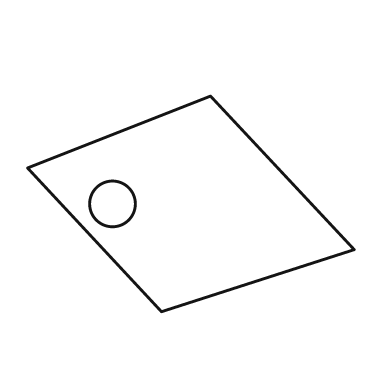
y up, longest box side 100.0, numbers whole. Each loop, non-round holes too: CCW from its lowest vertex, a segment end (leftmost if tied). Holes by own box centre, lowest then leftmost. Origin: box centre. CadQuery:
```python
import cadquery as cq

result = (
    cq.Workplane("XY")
    .moveTo(-9.0, -33.0)
    .lineTo(50.0, -14.0)
    .lineTo(6.0, 33.0)
    .lineTo(-50.0, 11.0)
    .close()
    .moveTo(-24.0, 0.0)
    .circle(7.0)
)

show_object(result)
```